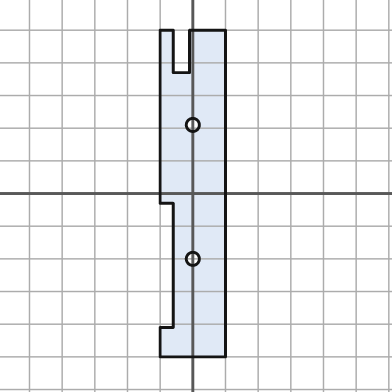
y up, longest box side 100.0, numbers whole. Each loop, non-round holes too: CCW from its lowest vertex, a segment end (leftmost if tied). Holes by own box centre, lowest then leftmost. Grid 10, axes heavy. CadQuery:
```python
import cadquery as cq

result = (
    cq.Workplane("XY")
    .moveTo(-10.0, -50.0)
    .lineTo(10.0, -50.0)
    .lineTo(10.0, 50.0)
    .lineTo(-1.0, 50.0)
    .lineTo(-1.0, 37.0)
    .lineTo(-6.0, 37.0)
    .lineTo(-6.0, 50.0)
    .lineTo(-10.0, 50.0)
    .lineTo(-10.0, -3.0)
    .lineTo(-6.0, -3.0)
    .lineTo(-6.0, -41.0)
    .lineTo(-10.0, -41.0)
    .close()
    .moveTo(0.0, -20.0)
    .circle(2.0)
    .moveTo(0.0, 21.0)
    .circle(2.0)
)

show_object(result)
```